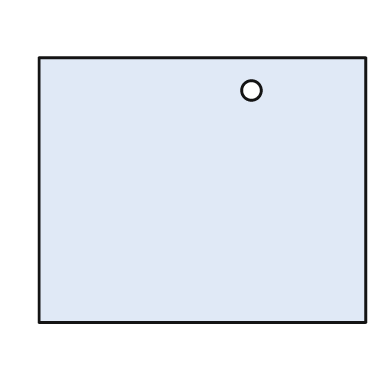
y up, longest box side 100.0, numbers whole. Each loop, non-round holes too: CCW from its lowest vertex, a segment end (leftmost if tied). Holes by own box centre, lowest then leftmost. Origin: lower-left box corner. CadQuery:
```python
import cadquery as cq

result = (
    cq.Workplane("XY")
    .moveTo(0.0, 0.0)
    .lineTo(100.0, 0.0)
    .lineTo(100.0, 81.0)
    .lineTo(0.0, 81.0)
    .close()
    .moveTo(65.0, 71.0)
    .circle(3.0)
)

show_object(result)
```